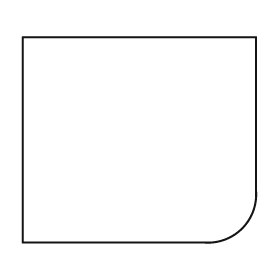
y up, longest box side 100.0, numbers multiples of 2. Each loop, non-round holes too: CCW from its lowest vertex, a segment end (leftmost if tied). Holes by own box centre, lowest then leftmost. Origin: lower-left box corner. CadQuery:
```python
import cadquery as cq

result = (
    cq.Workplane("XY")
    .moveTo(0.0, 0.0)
    .lineTo(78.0, 0.0)
    .threePointArc((94.0, 6.0), (100.0, 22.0))
    .lineTo(100.0, 88.0)
    .lineTo(0.0, 88.0)
    .close()
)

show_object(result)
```